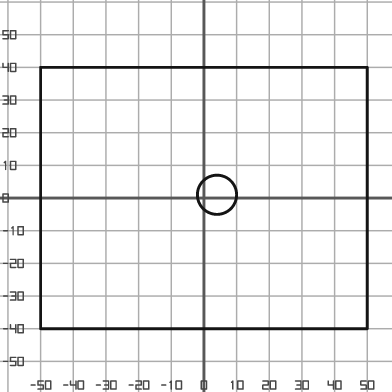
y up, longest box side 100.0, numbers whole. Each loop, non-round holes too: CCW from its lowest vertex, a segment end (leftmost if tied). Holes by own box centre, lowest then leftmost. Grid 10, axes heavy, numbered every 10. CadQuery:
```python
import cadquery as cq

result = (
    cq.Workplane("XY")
    .moveTo(-50.0, -40.0)
    .lineTo(50.0, -40.0)
    .lineTo(50.0, 40.0)
    .lineTo(-50.0, 40.0)
    .close()
    .moveTo(4.0, 1.0)
    .circle(6.0)
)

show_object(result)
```